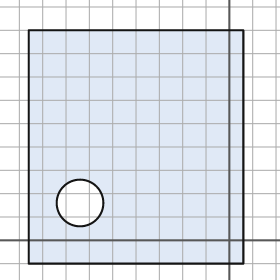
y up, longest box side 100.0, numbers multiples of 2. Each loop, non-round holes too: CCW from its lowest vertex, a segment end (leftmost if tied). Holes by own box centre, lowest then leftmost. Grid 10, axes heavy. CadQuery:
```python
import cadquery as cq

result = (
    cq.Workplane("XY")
    .moveTo(-86.0, -10.0)
    .lineTo(6.0, -10.0)
    .lineTo(6.0, 90.0)
    .lineTo(-86.0, 90.0)
    .close()
    .moveTo(-64.0, 16.0)
    .circle(10.0)
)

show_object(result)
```